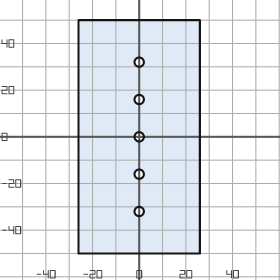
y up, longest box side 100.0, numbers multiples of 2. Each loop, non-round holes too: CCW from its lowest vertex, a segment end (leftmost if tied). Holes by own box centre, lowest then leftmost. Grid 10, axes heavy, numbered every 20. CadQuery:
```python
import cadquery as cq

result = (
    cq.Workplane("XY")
    .moveTo(-26.0, -50.0)
    .lineTo(26.0, -50.0)
    .lineTo(26.0, 50.0)
    .lineTo(-26.0, 50.0)
    .close()
    .moveTo(0.0, -32.0)
    .circle(2.0)
    .moveTo(0.0, -16.0)
    .circle(2.0)
    .moveTo(0.0, 0.0)
    .circle(2.0)
    .moveTo(0.0, 16.0)
    .circle(2.0)
    .moveTo(0.0, 32.0)
    .circle(2.0)
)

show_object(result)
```